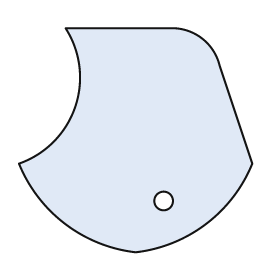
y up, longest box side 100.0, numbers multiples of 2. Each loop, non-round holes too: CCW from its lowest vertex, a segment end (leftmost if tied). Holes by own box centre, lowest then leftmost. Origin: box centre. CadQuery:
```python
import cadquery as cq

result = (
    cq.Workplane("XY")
    .moveTo(0.0, -48.0)
    .threePointArc((30.0, -36.0), (50.0, -10.0))
    .lineTo(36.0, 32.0)
    .threePointArc((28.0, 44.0), (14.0, 48.0))
    .lineTo(-30.0, 48.0)
    .threePointArc((-26.0, 14.0), (-50.0, -10.0))
    .threePointArc((-30.0, -36.0), (0.0, -48.0))
    .close()
    .moveTo(12.0, -26.0)
    .circle(4.0)
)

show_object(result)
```